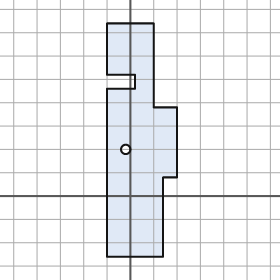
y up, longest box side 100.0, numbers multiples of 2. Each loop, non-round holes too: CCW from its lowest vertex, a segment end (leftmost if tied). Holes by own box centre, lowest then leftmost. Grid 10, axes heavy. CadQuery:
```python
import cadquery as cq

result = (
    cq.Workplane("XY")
    .moveTo(-10.0, -26.0)
    .lineTo(14.0, -26.0)
    .lineTo(14.0, 8.0)
    .lineTo(20.0, 8.0)
    .lineTo(20.0, 38.0)
    .lineTo(10.0, 38.0)
    .lineTo(10.0, 74.0)
    .lineTo(-10.0, 74.0)
    .lineTo(-10.0, 52.0)
    .lineTo(2.0, 52.0)
    .lineTo(2.0, 46.0)
    .lineTo(-10.0, 46.0)
    .close()
    .moveTo(-2.0, 20.0)
    .circle(2.0)
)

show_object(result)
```